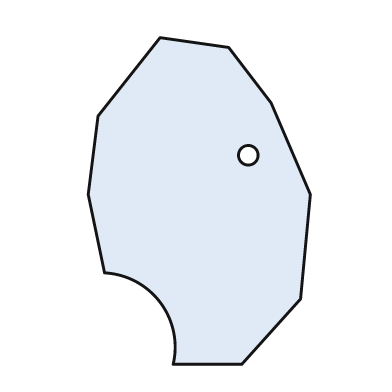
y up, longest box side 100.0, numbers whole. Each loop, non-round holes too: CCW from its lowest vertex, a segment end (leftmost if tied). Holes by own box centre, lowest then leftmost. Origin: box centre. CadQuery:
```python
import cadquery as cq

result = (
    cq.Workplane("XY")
    .moveTo(-8.0, -50.0)
    .lineTo(13.0, -50.0)
    .lineTo(31.0, -30.0)
    .lineTo(34.0, 2.0)
    .lineTo(22.0, 30.0)
    .lineTo(9.0, 47.0)
    .lineTo(-12.0, 50.0)
    .lineTo(-31.0, 26.0)
    .lineTo(-34.0, 2.0)
    .lineTo(-29.0, -22.0)
    .threePointArc((-12.0, -31.0), (-8.0, -50.0))
    .close()
    .moveTo(15.0, 14.0)
    .circle(3.0)
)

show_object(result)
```